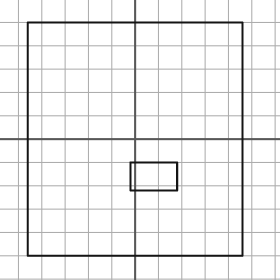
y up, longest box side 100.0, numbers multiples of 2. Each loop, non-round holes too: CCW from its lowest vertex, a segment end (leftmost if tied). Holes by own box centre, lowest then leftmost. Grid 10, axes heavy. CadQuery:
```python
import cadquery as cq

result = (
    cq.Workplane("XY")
    .moveTo(-46.0, -50.0)
    .lineTo(46.0, -50.0)
    .lineTo(46.0, 50.0)
    .lineTo(-46.0, 50.0)
    .close()
    .moveTo(-2.0, -22.0)
    .lineTo(18.0, -22.0)
    .lineTo(18.0, -10.0)
    .lineTo(-2.0, -10.0)
    .close()
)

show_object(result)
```